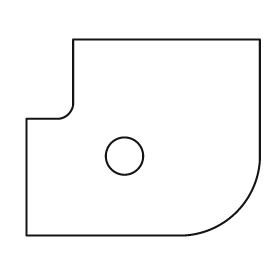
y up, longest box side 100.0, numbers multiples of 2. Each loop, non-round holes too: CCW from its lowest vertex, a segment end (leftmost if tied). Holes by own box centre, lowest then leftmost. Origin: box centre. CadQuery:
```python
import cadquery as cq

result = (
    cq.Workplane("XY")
    .moveTo(-50.0, -42.0)
    .lineTo(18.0, -42.0)
    .threePointArc((40.0, -32.0), (50.0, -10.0))
    .lineTo(50.0, 42.0)
    .lineTo(-30.0, 42.0)
    .lineTo(-30.0, 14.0)
    .threePointArc((-32.0, 10.0), (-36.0, 8.0))
    .lineTo(-50.0, 8.0)
    .close()
    .moveTo(-8.0, -8.0)
    .circle(8.0)
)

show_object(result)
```